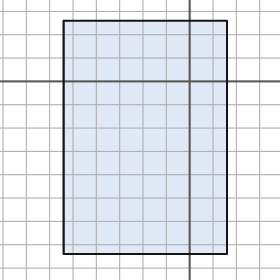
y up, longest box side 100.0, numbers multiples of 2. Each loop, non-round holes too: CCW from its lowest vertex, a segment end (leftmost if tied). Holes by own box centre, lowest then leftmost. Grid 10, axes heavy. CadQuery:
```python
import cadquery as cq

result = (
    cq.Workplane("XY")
    .moveTo(-54.0, -74.0)
    .lineTo(16.0, -74.0)
    .lineTo(16.0, 26.0)
    .lineTo(-54.0, 26.0)
    .close()
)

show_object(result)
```